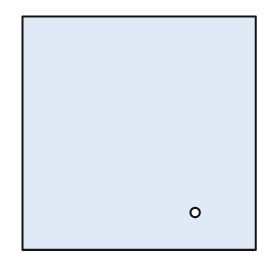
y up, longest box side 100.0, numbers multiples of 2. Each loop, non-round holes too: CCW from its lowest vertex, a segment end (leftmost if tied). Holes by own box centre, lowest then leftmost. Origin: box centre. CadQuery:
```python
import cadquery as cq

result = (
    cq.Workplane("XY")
    .moveTo(-50.0, -50.0)
    .lineTo(50.0, -50.0)
    .lineTo(50.0, 50.0)
    .lineTo(-50.0, 50.0)
    .close()
    .moveTo(24.0, -34.0)
    .circle(2.0)
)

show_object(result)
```